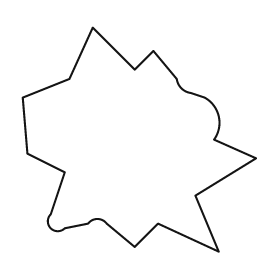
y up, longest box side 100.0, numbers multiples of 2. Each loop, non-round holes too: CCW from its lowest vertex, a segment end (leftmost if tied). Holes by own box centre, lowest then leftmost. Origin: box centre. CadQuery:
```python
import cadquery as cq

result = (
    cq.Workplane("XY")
    .moveTo(34.0, -48.0)
    .lineTo(24.0, -24.0)
    .lineTo(50.0, -8.0)
    .lineTo(32.0, 0.0)
    .threePointArc((34.0, 10.0), (28.0, 18.0))
    .lineTo(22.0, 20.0)
    .threePointArc((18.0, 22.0), (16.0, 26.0))
    .lineTo(6.0, 38.0)
    .lineTo(-2.0, 30.0)
    .lineTo(-20.0, 48.0)
    .lineTo(-30.0, 26.0)
    .lineTo(-50.0, 18.0)
    .lineTo(-48.0, -6.0)
    .lineTo(-32.0, -14.0)
    .lineTo(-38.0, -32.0)
    .threePointArc((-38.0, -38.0), (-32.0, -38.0))
    .lineTo(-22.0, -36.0)
    .threePointArc((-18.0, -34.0), (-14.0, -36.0))
    .lineTo(-2.0, -46.0)
    .lineTo(8.0, -36.0)
    .close()
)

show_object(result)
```